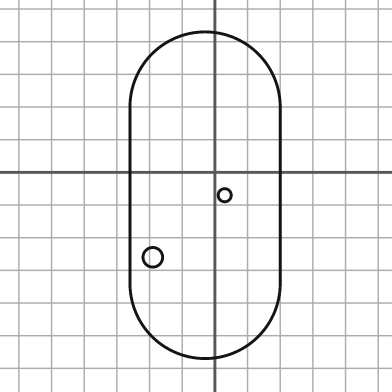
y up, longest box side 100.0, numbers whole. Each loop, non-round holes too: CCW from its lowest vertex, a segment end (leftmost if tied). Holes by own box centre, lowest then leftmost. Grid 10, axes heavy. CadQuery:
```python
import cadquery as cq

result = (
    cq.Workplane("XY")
    .moveTo(-26.0, -34.0)
    .threePointArc((-3.0, -57.0), (20.0, -34.0))
    .lineTo(20.0, 20.0)
    .threePointArc((-3.0, 43.0), (-26.0, 20.0))
    .close()
    .moveTo(-19.0, -26.0)
    .circle(3.0)
    .moveTo(3.0, -7.0)
    .circle(2.0)
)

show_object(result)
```